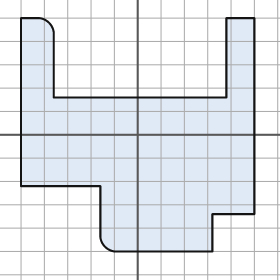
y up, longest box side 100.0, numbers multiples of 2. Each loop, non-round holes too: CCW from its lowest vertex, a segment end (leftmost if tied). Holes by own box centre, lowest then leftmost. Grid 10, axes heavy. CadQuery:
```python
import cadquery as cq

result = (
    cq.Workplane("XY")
    .moveTo(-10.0, -50.0)
    .lineTo(32.0, -50.0)
    .lineTo(32.0, -34.0)
    .lineTo(50.0, -34.0)
    .lineTo(50.0, 50.0)
    .lineTo(38.0, 50.0)
    .lineTo(38.0, 16.0)
    .lineTo(-36.0, 16.0)
    .lineTo(-36.0, 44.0)
    .threePointArc((-38.0, 48.0), (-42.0, 50.0))
    .lineTo(-50.0, 50.0)
    .lineTo(-50.0, -22.0)
    .lineTo(-16.0, -22.0)
    .lineTo(-16.0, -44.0)
    .threePointArc((-14.0, -48.0), (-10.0, -50.0))
    .close()
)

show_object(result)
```